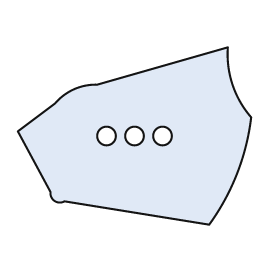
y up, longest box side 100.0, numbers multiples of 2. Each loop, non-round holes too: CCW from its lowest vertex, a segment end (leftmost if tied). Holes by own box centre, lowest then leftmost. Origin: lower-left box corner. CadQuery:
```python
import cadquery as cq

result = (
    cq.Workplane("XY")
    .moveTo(82.0, 0.0)
    .threePointArc((94.0, 22.0), (100.0, 46.0))
    .threePointArc((92.0, 60.0), (90.0, 76.0))
    .lineTo(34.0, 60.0)
    .threePointArc((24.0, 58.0), (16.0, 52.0))
    .lineTo(0.0, 40.0)
    .lineTo(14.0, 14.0)
    .threePointArc((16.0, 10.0), (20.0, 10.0))
    .close()
    .moveTo(38.0, 38.0)
    .circle(4.0)
    .moveTo(50.0, 38.0)
    .circle(4.0)
    .moveTo(62.0, 38.0)
    .circle(4.0)
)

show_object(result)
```